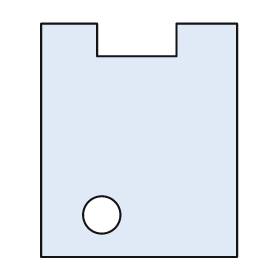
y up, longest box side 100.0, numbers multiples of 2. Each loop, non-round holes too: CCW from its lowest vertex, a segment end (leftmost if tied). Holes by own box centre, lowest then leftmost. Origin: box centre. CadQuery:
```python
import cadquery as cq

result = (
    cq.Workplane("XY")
    .moveTo(-42.0, -50.0)
    .lineTo(42.0, -50.0)
    .lineTo(42.0, 50.0)
    .lineTo(16.0, 50.0)
    .lineTo(16.0, 36.0)
    .lineTo(-18.0, 36.0)
    .lineTo(-18.0, 50.0)
    .lineTo(-42.0, 50.0)
    .close()
    .moveTo(-16.0, -32.0)
    .circle(8.0)
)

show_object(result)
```